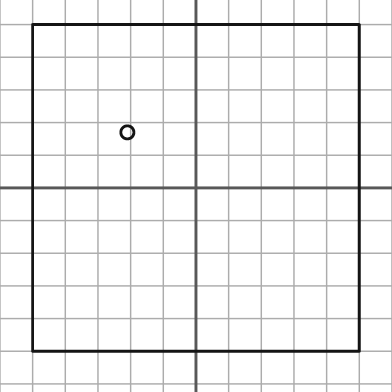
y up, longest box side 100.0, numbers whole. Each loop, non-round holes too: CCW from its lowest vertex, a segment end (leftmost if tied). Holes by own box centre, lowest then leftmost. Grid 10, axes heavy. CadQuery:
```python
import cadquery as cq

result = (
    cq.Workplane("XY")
    .moveTo(-50.0, -50.0)
    .lineTo(50.0, -50.0)
    .lineTo(50.0, 50.0)
    .lineTo(-50.0, 50.0)
    .close()
    .moveTo(-21.0, 17.0)
    .circle(2.0)
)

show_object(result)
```